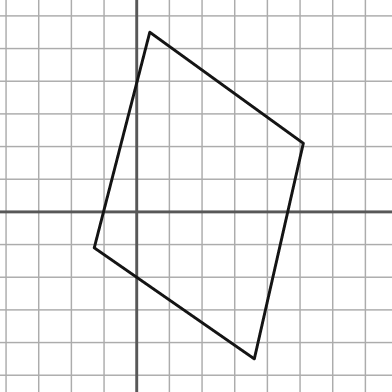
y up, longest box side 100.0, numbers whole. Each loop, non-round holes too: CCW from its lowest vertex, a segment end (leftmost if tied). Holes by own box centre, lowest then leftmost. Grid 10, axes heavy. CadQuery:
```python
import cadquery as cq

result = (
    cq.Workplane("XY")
    .moveTo(36.0, -45.0)
    .lineTo(51.0, 21.0)
    .lineTo(4.0, 55.0)
    .lineTo(-13.0, -11.0)
    .close()
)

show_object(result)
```